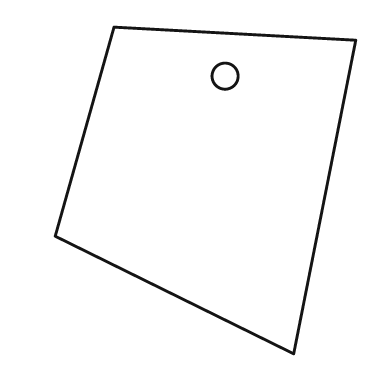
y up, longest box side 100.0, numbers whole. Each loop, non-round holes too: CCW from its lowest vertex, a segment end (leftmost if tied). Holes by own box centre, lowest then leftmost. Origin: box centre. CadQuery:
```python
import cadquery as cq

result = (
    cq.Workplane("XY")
    .moveTo(27.0, -50.0)
    .lineTo(46.0, 46.0)
    .lineTo(-28.0, 50.0)
    .lineTo(-46.0, -14.0)
    .close()
    .moveTo(6.0, 35.0)
    .circle(4.0)
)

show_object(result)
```